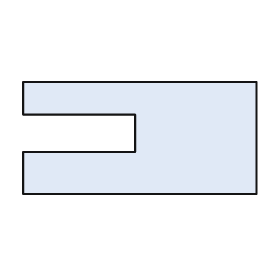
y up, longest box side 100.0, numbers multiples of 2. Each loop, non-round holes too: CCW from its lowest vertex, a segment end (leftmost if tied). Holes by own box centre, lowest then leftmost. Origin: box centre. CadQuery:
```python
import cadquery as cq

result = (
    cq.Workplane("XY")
    .moveTo(-50.0, -24.0)
    .lineTo(50.0, -24.0)
    .lineTo(50.0, 24.0)
    .lineTo(-50.0, 24.0)
    .lineTo(-50.0, 10.0)
    .lineTo(-2.0, 10.0)
    .lineTo(-2.0, -6.0)
    .lineTo(-50.0, -6.0)
    .close()
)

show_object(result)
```